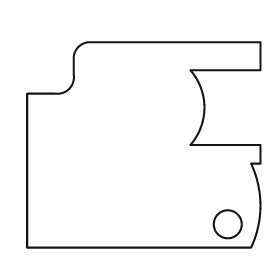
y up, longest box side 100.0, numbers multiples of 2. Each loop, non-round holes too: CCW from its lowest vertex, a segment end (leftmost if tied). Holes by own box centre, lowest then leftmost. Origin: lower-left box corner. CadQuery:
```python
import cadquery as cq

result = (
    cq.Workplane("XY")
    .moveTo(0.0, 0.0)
    .lineTo(96.0, 0.0)
    .threePointArc((100.0, 18.0), (96.0, 36.0))
    .lineTo(100.0, 36.0)
    .lineTo(100.0, 44.0)
    .lineTo(70.0, 44.0)
    .threePointArc((76.0, 60.0), (70.0, 76.0))
    .lineTo(100.0, 76.0)
    .lineTo(100.0, 88.0)
    .lineTo(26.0, 88.0)
    .threePointArc((22.0, 86.0), (20.0, 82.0))
    .lineTo(20.0, 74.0)
    .threePointArc((18.0, 68.0), (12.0, 66.0))
    .lineTo(0.0, 66.0)
    .close()
    .moveTo(86.0, 10.0)
    .circle(6.0)
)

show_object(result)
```